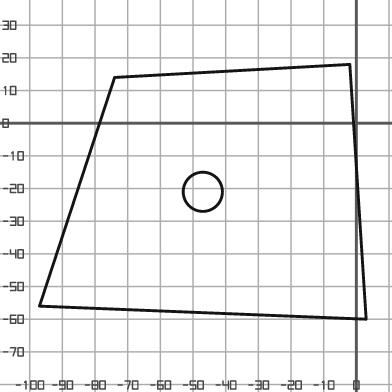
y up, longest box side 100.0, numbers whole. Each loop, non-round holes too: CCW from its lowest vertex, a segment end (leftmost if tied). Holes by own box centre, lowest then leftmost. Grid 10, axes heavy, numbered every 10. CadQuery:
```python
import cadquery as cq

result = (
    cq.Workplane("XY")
    .moveTo(3.0, -60.0)
    .lineTo(-2.0, 18.0)
    .lineTo(-74.0, 14.0)
    .lineTo(-97.0, -56.0)
    .close()
    .moveTo(-47.0, -21.0)
    .circle(6.0)
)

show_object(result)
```